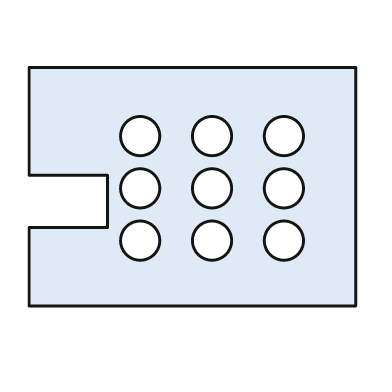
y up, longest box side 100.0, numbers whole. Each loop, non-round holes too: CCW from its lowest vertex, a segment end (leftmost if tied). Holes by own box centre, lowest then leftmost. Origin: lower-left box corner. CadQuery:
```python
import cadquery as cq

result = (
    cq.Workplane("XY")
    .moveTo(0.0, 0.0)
    .lineTo(100.0, 0.0)
    .lineTo(100.0, 73.0)
    .lineTo(0.0, 73.0)
    .lineTo(0.0, 40.0)
    .lineTo(24.0, 40.0)
    .lineTo(24.0, 24.0)
    .lineTo(0.0, 24.0)
    .close()
    .moveTo(34.0, 20.0)
    .circle(6.0)
    .moveTo(56.0, 20.0)
    .circle(6.0)
    .moveTo(78.0, 20.0)
    .circle(6.0)
    .moveTo(34.0, 36.0)
    .circle(6.0)
    .moveTo(56.0, 36.0)
    .circle(6.0)
    .moveTo(78.0, 36.0)
    .circle(6.0)
    .moveTo(34.0, 52.0)
    .circle(6.0)
    .moveTo(56.0, 52.0)
    .circle(6.0)
    .moveTo(78.0, 52.0)
    .circle(6.0)
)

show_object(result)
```